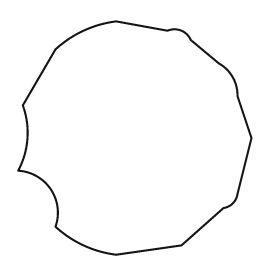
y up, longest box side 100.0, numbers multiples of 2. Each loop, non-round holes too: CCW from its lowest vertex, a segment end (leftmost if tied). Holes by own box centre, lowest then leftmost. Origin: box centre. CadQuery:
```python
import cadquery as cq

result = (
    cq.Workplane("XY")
    .moveTo(-8.0, -50.0)
    .lineTo(20.0, -46.0)
    .lineTo(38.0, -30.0)
    .threePointArc((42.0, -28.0), (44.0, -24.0))
    .lineTo(50.0, 0.0)
    .lineTo(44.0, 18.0)
    .threePointArc((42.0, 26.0), (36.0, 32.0))
    .lineTo(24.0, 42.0)
    .threePointArc((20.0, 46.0), (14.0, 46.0))
    .lineTo(-8.0, 50.0)
    .threePointArc((-22.0, 46.0), (-34.0, 38.0))
    .lineTo(-48.0, 14.0)
    .threePointArc((-46.0, 0.0), (-50.0, -14.0))
    .threePointArc((-36.0, -22.0), (-34.0, -38.0))
    .threePointArc((-22.0, -46.0), (-8.0, -50.0))
    .close()
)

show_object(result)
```